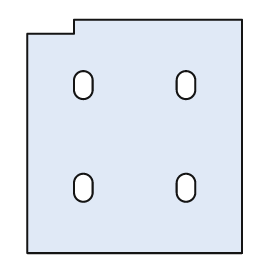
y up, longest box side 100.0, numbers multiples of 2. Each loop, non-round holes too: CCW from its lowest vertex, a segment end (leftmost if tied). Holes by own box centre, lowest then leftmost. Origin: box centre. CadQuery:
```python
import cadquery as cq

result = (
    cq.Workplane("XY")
    .moveTo(-46.0, -50.0)
    .lineTo(46.0, -50.0)
    .lineTo(46.0, 50.0)
    .lineTo(-26.0, 50.0)
    .lineTo(-26.0, 44.0)
    .lineTo(-46.0, 44.0)
    .close()
    .moveTo(-26.0, -24.0)
    .threePointArc((-22.0, -28.0), (-18.0, -24.0))
    .lineTo(-18.0, -20.0)
    .threePointArc((-22.0, -16.0), (-26.0, -20.0))
    .close()
    .moveTo(18.0, -24.0)
    .threePointArc((22.0, -28.0), (26.0, -24.0))
    .lineTo(26.0, -20.0)
    .threePointArc((22.0, -16.0), (18.0, -20.0))
    .close()
    .moveTo(-26.0, 20.0)
    .threePointArc((-22.0, 16.0), (-18.0, 20.0))
    .lineTo(-18.0, 24.0)
    .threePointArc((-22.0, 28.0), (-26.0, 24.0))
    .close()
    .moveTo(18.0, 20.0)
    .threePointArc((22.0, 16.0), (26.0, 20.0))
    .lineTo(26.0, 24.0)
    .threePointArc((22.0, 28.0), (18.0, 24.0))
    .close()
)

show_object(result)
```